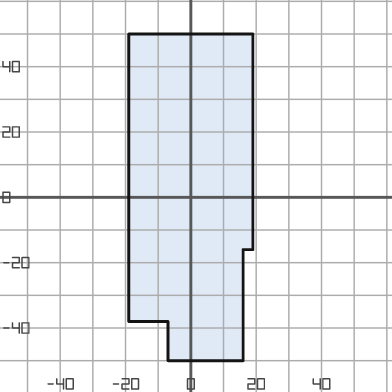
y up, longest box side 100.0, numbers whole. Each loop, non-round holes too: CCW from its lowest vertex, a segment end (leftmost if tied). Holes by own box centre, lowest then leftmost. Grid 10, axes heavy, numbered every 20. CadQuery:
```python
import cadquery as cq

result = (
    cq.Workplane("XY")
    .moveTo(-7.0, -50.0)
    .lineTo(16.0, -50.0)
    .lineTo(16.0, -16.0)
    .lineTo(19.0, -16.0)
    .lineTo(19.0, 50.0)
    .lineTo(-19.0, 50.0)
    .lineTo(-19.0, -38.0)
    .lineTo(-7.0, -38.0)
    .close()
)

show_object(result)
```